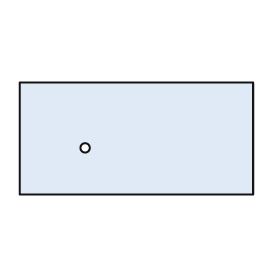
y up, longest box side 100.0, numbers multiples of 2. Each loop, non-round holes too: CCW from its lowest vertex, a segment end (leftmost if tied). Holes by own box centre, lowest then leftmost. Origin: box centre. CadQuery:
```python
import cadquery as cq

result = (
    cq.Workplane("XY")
    .moveTo(-50.0, -24.0)
    .lineTo(50.0, -24.0)
    .lineTo(50.0, 24.0)
    .lineTo(-50.0, 24.0)
    .close()
    .moveTo(-22.0, -4.0)
    .circle(2.0)
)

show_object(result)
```